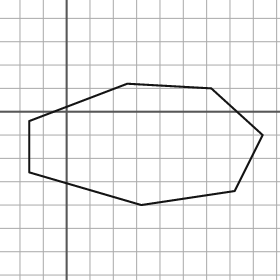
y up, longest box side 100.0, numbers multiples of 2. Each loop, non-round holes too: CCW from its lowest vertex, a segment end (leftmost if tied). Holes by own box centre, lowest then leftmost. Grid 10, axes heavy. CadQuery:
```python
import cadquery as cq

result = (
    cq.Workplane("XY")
    .moveTo(32.0, -40.0)
    .lineTo(72.0, -34.0)
    .lineTo(84.0, -10.0)
    .lineTo(62.0, 10.0)
    .lineTo(26.0, 12.0)
    .lineTo(-16.0, -4.0)
    .lineTo(-16.0, -26.0)
    .close()
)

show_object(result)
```